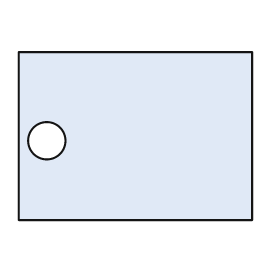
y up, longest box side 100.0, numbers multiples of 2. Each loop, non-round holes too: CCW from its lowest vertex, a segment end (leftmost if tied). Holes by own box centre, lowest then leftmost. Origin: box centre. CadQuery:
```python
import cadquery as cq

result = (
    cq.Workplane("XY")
    .moveTo(-50.0, -36.0)
    .lineTo(50.0, -36.0)
    .lineTo(50.0, 36.0)
    .lineTo(-50.0, 36.0)
    .close()
    .moveTo(-38.0, -2.0)
    .circle(8.0)
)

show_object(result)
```